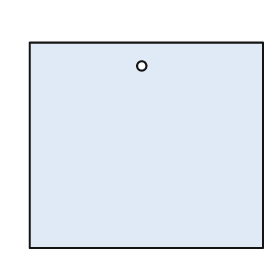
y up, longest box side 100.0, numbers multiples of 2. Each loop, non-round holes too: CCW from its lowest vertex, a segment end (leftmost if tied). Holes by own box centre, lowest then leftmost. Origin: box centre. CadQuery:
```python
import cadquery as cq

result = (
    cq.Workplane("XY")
    .moveTo(-50.0, -44.0)
    .lineTo(50.0, -44.0)
    .lineTo(50.0, 44.0)
    .lineTo(-50.0, 44.0)
    .close()
    .moveTo(-2.0, 34.0)
    .circle(2.0)
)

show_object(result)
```